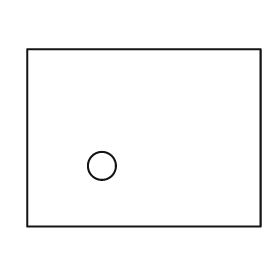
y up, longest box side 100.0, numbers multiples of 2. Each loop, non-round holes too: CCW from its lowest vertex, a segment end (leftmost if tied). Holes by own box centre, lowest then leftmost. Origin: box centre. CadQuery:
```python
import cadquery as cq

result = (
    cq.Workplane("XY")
    .moveTo(-50.0, -38.0)
    .lineTo(50.0, -38.0)
    .lineTo(50.0, 38.0)
    .lineTo(-50.0, 38.0)
    .close()
    .moveTo(-18.0, -12.0)
    .circle(6.0)
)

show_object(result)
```